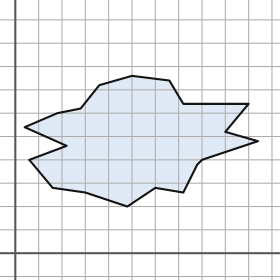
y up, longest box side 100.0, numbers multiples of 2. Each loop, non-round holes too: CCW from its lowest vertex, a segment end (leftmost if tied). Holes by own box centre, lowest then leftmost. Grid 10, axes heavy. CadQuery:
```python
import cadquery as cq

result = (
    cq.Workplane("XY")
    .moveTo(48.0, 20.0)
    .lineTo(60.0, 28.0)
    .lineTo(72.0, 26.0)
    .lineTo(78.0, 38.0)
    .lineTo(80.0, 40.0)
    .lineTo(104.0, 48.0)
    .lineTo(90.0, 52.0)
    .lineTo(100.0, 64.0)
    .lineTo(72.0, 64.0)
    .lineTo(66.0, 74.0)
    .lineTo(50.0, 76.0)
    .lineTo(36.0, 72.0)
    .lineTo(28.0, 62.0)
    .lineTo(18.0, 60.0)
    .lineTo(4.0, 54.0)
    .lineTo(22.0, 46.0)
    .lineTo(6.0, 40.0)
    .lineTo(16.0, 28.0)
    .lineTo(30.0, 26.0)
    .close()
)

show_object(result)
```